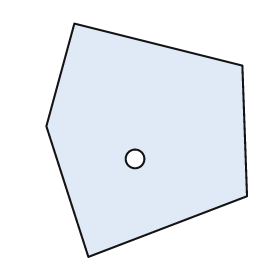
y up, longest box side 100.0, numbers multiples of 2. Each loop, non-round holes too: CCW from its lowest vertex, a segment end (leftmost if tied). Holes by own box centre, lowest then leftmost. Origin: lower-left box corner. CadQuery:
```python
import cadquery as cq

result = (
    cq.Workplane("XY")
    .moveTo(18.0, 0.0)
    .lineTo(86.0, 26.0)
    .lineTo(84.0, 82.0)
    .lineTo(12.0, 100.0)
    .lineTo(0.0, 56.0)
    .close()
    .moveTo(38.0, 42.0)
    .circle(4.0)
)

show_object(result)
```